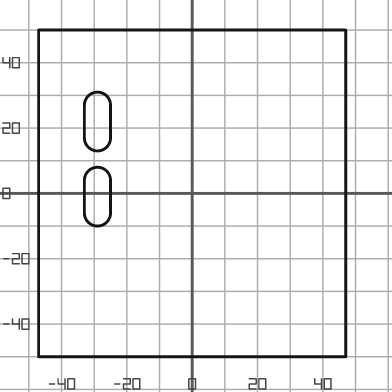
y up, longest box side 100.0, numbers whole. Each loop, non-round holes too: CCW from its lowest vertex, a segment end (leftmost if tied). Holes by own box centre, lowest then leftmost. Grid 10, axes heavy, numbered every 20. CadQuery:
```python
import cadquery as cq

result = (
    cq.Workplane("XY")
    .moveTo(-47.0, -50.0)
    .lineTo(47.0, -50.0)
    .lineTo(47.0, 50.0)
    .lineTo(-47.0, 50.0)
    .close()
    .moveTo(-33.0, -6.0)
    .threePointArc((-29.0, -10.0), (-25.0, -6.0))
    .lineTo(-25.0, 4.0)
    .threePointArc((-29.0, 8.0), (-33.0, 4.0))
    .close()
    .moveTo(-33.0, 17.0)
    .threePointArc((-29.0, 13.0), (-25.0, 17.0))
    .lineTo(-25.0, 27.0)
    .threePointArc((-29.0, 31.0), (-33.0, 27.0))
    .close()
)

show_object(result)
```